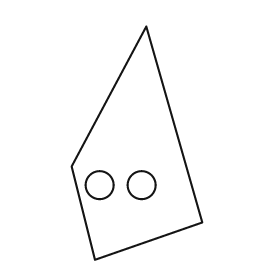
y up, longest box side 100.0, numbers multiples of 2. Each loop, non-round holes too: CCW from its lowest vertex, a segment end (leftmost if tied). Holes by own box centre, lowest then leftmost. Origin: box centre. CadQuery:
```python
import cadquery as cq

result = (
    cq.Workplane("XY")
    .moveTo(-18.0, -50.0)
    .lineTo(28.0, -34.0)
    .lineTo(4.0, 50.0)
    .lineTo(-28.0, -10.0)
    .close()
    .moveTo(-16.0, -18.0)
    .circle(6.0)
    .moveTo(2.0, -18.0)
    .circle(6.0)
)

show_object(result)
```